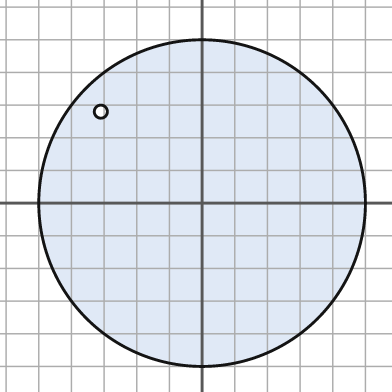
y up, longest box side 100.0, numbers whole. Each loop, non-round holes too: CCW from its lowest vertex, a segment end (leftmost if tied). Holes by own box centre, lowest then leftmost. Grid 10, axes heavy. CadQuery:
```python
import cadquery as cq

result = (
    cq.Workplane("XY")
    .moveTo(0.0, 0.0)
    .circle(50.0)
    .moveTo(-31.0, 28.0)
    .circle(2.0)
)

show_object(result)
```